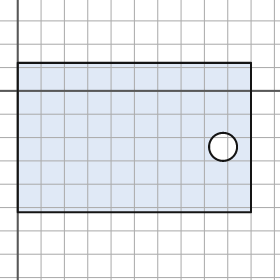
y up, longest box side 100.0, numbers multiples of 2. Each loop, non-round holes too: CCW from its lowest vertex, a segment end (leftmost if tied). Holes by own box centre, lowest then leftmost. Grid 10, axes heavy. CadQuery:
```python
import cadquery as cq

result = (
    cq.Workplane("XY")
    .moveTo(0.0, -52.0)
    .lineTo(100.0, -52.0)
    .lineTo(100.0, 12.0)
    .lineTo(0.0, 12.0)
    .close()
    .moveTo(88.0, -24.0)
    .circle(6.0)
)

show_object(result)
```